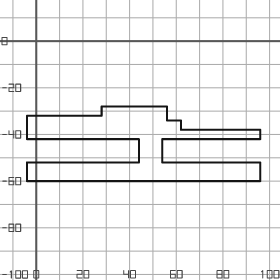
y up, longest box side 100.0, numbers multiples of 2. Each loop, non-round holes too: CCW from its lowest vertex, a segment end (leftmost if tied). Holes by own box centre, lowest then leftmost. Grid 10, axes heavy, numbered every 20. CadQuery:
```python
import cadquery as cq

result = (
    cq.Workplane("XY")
    .moveTo(-4.0, -60.0)
    .lineTo(96.0, -60.0)
    .lineTo(96.0, -52.0)
    .lineTo(54.0, -52.0)
    .lineTo(54.0, -42.0)
    .lineTo(96.0, -42.0)
    .lineTo(96.0, -38.0)
    .lineTo(62.0, -38.0)
    .lineTo(62.0, -34.0)
    .lineTo(56.0, -34.0)
    .lineTo(56.0, -28.0)
    .lineTo(28.0, -28.0)
    .lineTo(28.0, -32.0)
    .lineTo(-4.0, -32.0)
    .lineTo(-4.0, -42.0)
    .lineTo(44.0, -42.0)
    .lineTo(44.0, -52.0)
    .lineTo(-4.0, -52.0)
    .close()
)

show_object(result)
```